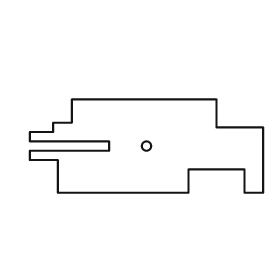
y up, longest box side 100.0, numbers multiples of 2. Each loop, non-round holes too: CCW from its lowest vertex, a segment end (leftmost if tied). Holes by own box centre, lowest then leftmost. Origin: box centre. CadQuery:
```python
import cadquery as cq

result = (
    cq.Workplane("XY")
    .moveTo(-38.0, -20.0)
    .lineTo(18.0, -20.0)
    .lineTo(18.0, -10.0)
    .lineTo(42.0, -10.0)
    .lineTo(42.0, -20.0)
    .lineTo(50.0, -20.0)
    .lineTo(50.0, 8.0)
    .lineTo(30.0, 8.0)
    .lineTo(30.0, 20.0)
    .lineTo(-32.0, 20.0)
    .lineTo(-32.0, 10.0)
    .lineTo(-40.0, 10.0)
    .lineTo(-40.0, 6.0)
    .lineTo(-50.0, 6.0)
    .lineTo(-50.0, 2.0)
    .lineTo(-16.0, 2.0)
    .lineTo(-16.0, -2.0)
    .lineTo(-50.0, -2.0)
    .lineTo(-50.0, -6.0)
    .lineTo(-38.0, -6.0)
    .close()
    .moveTo(0.0, 0.0)
    .circle(2.0)
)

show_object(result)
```